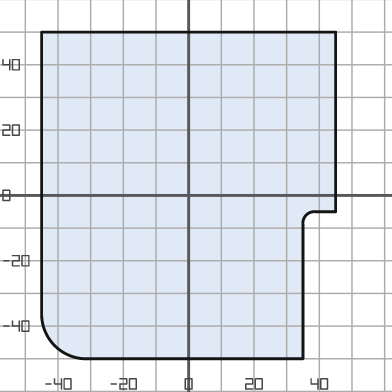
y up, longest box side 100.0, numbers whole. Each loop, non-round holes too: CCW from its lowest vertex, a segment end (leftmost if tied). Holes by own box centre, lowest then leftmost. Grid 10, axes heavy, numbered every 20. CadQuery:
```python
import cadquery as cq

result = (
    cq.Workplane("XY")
    .moveTo(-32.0, -50.0)
    .lineTo(35.0, -50.0)
    .lineTo(35.0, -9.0)
    .threePointArc((36.0, -6.0), (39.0, -5.0))
    .lineTo(45.0, -5.0)
    .lineTo(45.0, 50.0)
    .lineTo(-45.0, 50.0)
    .lineTo(-45.0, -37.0)
    .threePointArc((-41.0, -46.0), (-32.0, -50.0))
    .close()
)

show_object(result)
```